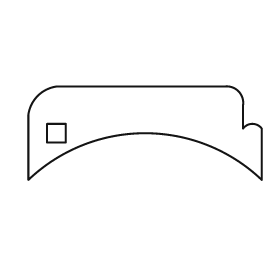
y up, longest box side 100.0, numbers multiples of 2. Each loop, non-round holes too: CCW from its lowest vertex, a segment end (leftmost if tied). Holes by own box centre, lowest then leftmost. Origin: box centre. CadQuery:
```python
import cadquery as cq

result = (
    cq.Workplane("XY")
    .moveTo(-50.0, -20.0)
    .threePointArc((0.0, 0.0), (50.0, -20.0))
    .lineTo(50.0, 2.0)
    .threePointArc((46.0, 4.0), (42.0, 2.0))
    .lineTo(42.0, 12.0)
    .threePointArc((40.0, 18.0), (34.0, 20.0))
    .lineTo(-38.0, 20.0)
    .threePointArc((-46.0, 16.0), (-50.0, 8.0))
    .close()
    .moveTo(-42.0, -4.0)
    .lineTo(-34.0, -4.0)
    .lineTo(-34.0, 4.0)
    .lineTo(-42.0, 4.0)
    .close()
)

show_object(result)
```